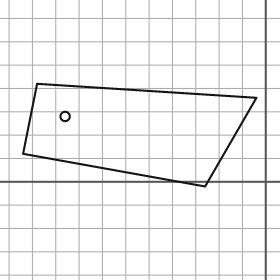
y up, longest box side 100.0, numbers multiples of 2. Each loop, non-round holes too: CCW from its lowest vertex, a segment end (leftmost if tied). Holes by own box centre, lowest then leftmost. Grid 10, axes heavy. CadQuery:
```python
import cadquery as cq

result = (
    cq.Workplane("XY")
    .moveTo(-26.0, -2.0)
    .lineTo(-4.0, 36.0)
    .lineTo(-98.0, 42.0)
    .lineTo(-104.0, 12.0)
    .close()
    .moveTo(-86.0, 28.0)
    .circle(2.0)
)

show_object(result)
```